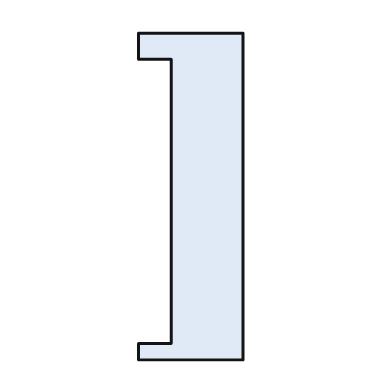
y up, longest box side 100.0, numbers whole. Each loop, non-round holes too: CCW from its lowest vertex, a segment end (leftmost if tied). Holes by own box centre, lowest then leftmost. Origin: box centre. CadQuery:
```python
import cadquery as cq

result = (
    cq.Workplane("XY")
    .moveTo(-16.0, -50.0)
    .lineTo(16.0, -50.0)
    .lineTo(16.0, 50.0)
    .lineTo(-16.0, 50.0)
    .lineTo(-16.0, 42.0)
    .lineTo(-6.0, 42.0)
    .lineTo(-6.0, -45.0)
    .lineTo(-16.0, -45.0)
    .close()
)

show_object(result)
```